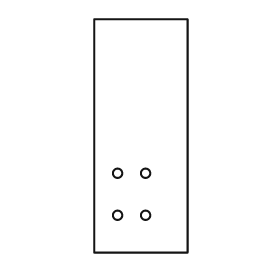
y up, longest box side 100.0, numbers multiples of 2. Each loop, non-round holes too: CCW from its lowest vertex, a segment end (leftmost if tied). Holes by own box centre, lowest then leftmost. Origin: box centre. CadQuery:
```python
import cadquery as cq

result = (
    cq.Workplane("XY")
    .moveTo(-20.0, -50.0)
    .lineTo(20.0, -50.0)
    .lineTo(20.0, 50.0)
    .lineTo(-20.0, 50.0)
    .close()
    .moveTo(-10.0, -34.0)
    .circle(2.0)
    .moveTo(2.0, -34.0)
    .circle(2.0)
    .moveTo(-10.0, -16.0)
    .circle(2.0)
    .moveTo(2.0, -16.0)
    .circle(2.0)
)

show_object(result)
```